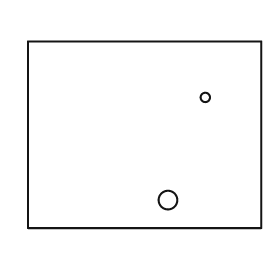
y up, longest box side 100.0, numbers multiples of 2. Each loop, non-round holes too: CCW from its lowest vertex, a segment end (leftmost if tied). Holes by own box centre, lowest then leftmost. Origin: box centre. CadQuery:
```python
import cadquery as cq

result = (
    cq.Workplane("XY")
    .moveTo(-50.0, -40.0)
    .lineTo(50.0, -40.0)
    .lineTo(50.0, 40.0)
    .lineTo(-50.0, 40.0)
    .close()
    .moveTo(10.0, -28.0)
    .circle(4.0)
    .moveTo(26.0, 16.0)
    .circle(2.0)
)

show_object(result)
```